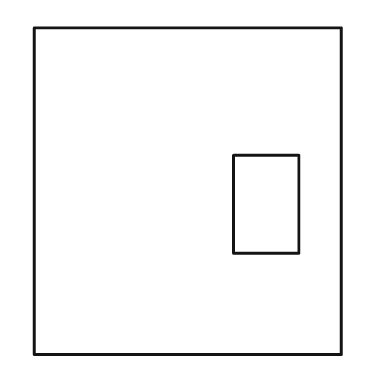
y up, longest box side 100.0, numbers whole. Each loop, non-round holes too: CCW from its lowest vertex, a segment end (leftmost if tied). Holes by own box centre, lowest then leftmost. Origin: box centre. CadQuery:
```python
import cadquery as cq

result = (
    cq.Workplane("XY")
    .moveTo(-47.0, -50.0)
    .lineTo(47.0, -50.0)
    .lineTo(47.0, 50.0)
    .lineTo(-47.0, 50.0)
    .close()
    .moveTo(14.0, -19.0)
    .lineTo(34.0, -19.0)
    .lineTo(34.0, 11.0)
    .lineTo(14.0, 11.0)
    .close()
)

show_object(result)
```